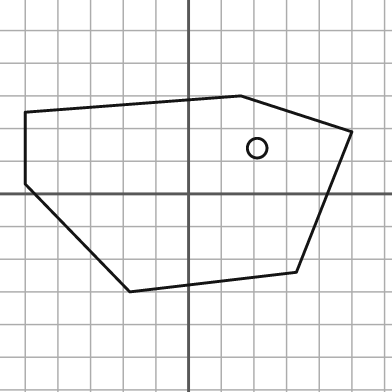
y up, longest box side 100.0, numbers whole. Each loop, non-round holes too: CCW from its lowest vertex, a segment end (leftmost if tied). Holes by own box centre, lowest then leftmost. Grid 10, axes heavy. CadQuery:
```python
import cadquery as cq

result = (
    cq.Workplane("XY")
    .moveTo(-18.0, -30.0)
    .lineTo(33.0, -24.0)
    .lineTo(50.0, 19.0)
    .lineTo(16.0, 30.0)
    .lineTo(-50.0, 25.0)
    .lineTo(-50.0, 3.0)
    .close()
    .moveTo(21.0, 14.0)
    .circle(3.0)
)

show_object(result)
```